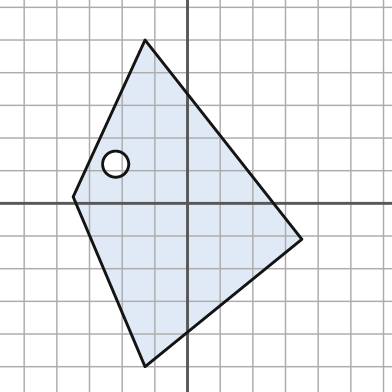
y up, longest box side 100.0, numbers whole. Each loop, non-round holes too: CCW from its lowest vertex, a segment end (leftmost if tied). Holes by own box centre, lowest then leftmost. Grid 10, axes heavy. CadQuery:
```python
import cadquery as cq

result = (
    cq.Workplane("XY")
    .moveTo(-13.0, -50.0)
    .lineTo(35.0, -11.0)
    .lineTo(-13.0, 50.0)
    .lineTo(-35.0, 2.0)
    .close()
    .moveTo(-22.0, 12.0)
    .circle(4.0)
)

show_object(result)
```